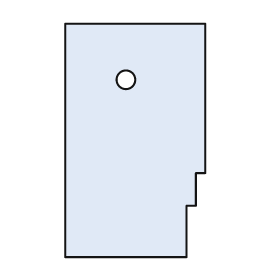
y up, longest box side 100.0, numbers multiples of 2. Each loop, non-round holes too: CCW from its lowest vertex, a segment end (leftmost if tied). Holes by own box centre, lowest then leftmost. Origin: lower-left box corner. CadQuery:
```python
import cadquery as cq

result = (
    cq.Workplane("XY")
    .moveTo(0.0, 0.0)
    .lineTo(52.0, 0.0)
    .lineTo(52.0, 22.0)
    .lineTo(56.0, 22.0)
    .lineTo(56.0, 36.0)
    .lineTo(60.0, 36.0)
    .lineTo(60.0, 100.0)
    .lineTo(0.0, 100.0)
    .close()
    .moveTo(26.0, 76.0)
    .circle(4.0)
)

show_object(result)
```